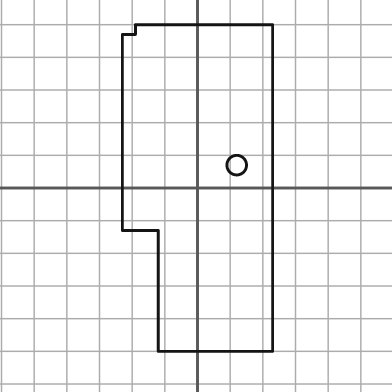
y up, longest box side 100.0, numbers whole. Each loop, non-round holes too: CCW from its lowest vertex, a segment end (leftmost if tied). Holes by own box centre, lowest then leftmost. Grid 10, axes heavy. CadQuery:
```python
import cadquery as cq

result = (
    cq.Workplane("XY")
    .moveTo(-12.0, -50.0)
    .lineTo(23.0, -50.0)
    .lineTo(23.0, 50.0)
    .lineTo(-19.0, 50.0)
    .lineTo(-19.0, 47.0)
    .lineTo(-23.0, 47.0)
    .lineTo(-23.0, -13.0)
    .lineTo(-12.0, -13.0)
    .close()
    .moveTo(12.0, 7.0)
    .circle(3.0)
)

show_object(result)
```